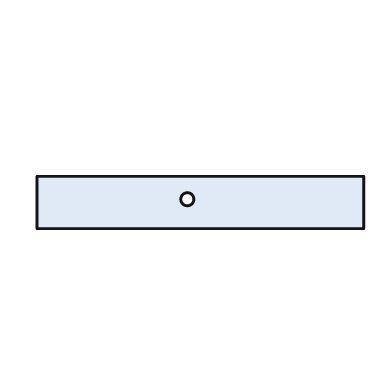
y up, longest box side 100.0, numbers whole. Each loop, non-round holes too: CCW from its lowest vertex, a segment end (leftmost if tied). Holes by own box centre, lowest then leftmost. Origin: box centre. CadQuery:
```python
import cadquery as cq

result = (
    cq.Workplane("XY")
    .moveTo(-50.0, -8.0)
    .lineTo(50.0, -8.0)
    .lineTo(50.0, 8.0)
    .lineTo(-50.0, 8.0)
    .close()
    .moveTo(-4.0, 1.0)
    .circle(2.0)
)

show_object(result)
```